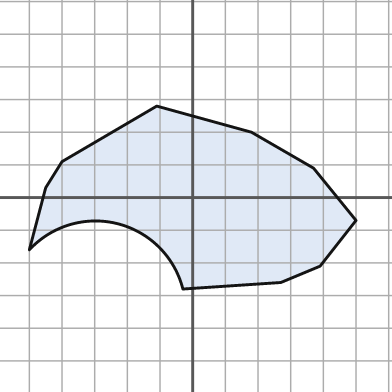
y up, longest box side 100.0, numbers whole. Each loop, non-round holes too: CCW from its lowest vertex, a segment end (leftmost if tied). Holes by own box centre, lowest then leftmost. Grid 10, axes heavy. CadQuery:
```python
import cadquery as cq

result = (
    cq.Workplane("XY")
    .moveTo(-3.0, -28.0)
    .lineTo(27.0, -26.0)
    .lineTo(39.0, -21.0)
    .lineTo(50.0, -7.0)
    .lineTo(37.0, 9.0)
    .lineTo(18.0, 20.0)
    .lineTo(-11.0, 28.0)
    .lineTo(-40.0, 11.0)
    .lineTo(-45.0, 3.0)
    .lineTo(-50.0, -16.0)
    .threePointArc((-23.0, -8.0), (-3.0, -28.0))
    .close()
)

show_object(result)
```